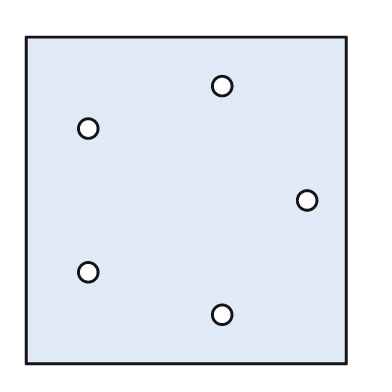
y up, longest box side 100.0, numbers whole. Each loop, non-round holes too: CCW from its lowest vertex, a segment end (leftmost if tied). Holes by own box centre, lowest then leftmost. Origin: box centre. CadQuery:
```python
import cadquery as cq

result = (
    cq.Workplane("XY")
    .moveTo(-49.0, -50.0)
    .lineTo(49.0, -50.0)
    .lineTo(49.0, 50.0)
    .lineTo(-49.0, 50.0)
    .close()
    .moveTo(11.0, -35.0)
    .circle(3.0)
    .moveTo(-30.0, -22.0)
    .circle(3.0)
    .moveTo(37.0, 0.0)
    .circle(3.0)
    .moveTo(-30.0, 22.0)
    .circle(3.0)
    .moveTo(11.0, 35.0)
    .circle(3.0)
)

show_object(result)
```